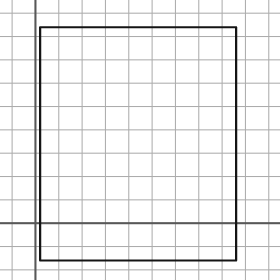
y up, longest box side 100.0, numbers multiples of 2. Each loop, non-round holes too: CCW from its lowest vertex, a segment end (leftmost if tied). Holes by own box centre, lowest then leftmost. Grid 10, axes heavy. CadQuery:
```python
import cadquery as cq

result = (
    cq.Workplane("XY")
    .moveTo(2.0, -16.0)
    .lineTo(86.0, -16.0)
    .lineTo(86.0, 84.0)
    .lineTo(2.0, 84.0)
    .close()
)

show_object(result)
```